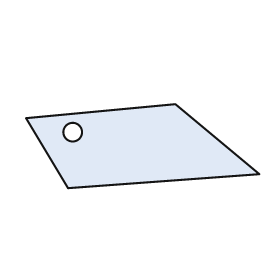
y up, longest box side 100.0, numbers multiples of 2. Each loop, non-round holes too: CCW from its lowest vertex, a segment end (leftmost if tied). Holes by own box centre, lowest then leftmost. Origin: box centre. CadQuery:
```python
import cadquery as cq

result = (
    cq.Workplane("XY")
    .moveTo(-32.0, -18.0)
    .lineTo(50.0, -12.0)
    .lineTo(14.0, 18.0)
    .lineTo(-50.0, 12.0)
    .close()
    .moveTo(-30.0, 6.0)
    .circle(4.0)
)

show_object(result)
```